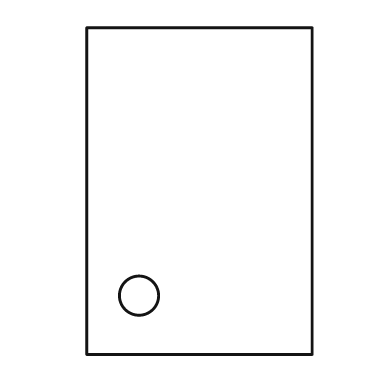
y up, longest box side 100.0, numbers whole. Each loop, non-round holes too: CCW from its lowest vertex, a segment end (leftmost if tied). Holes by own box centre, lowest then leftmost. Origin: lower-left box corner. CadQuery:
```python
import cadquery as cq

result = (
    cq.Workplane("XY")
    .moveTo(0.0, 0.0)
    .lineTo(69.0, 0.0)
    .lineTo(69.0, 100.0)
    .lineTo(0.0, 100.0)
    .close()
    .moveTo(16.0, 18.0)
    .circle(6.0)
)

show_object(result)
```